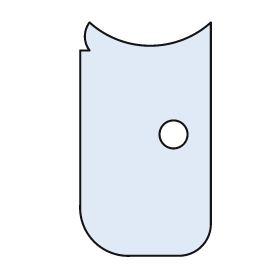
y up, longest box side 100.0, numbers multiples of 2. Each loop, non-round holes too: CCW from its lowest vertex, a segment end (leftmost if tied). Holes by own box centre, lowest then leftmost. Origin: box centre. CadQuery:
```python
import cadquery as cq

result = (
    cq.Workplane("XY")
    .moveTo(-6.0, -50.0)
    .lineTo(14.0, -50.0)
    .threePointArc((24.0, -46.0), (28.0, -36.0))
    .lineTo(28.0, 50.0)
    .threePointArc((2.0, 40.0), (-24.0, 50.0))
    .threePointArc((-26.0, 44.0), (-24.0, 38.0))
    .lineTo(-28.0, 38.0)
    .lineTo(-28.0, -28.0)
    .threePointArc((-22.0, -44.0), (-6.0, -50.0))
    .close()
    .moveTo(12.0, 2.0)
    .circle(6.0)
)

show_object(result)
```